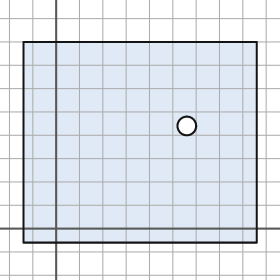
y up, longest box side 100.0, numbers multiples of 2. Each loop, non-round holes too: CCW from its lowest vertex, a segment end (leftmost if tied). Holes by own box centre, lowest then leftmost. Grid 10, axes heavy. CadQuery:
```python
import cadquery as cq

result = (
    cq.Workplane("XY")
    .moveTo(-14.0, -6.0)
    .lineTo(86.0, -6.0)
    .lineTo(86.0, 80.0)
    .lineTo(-14.0, 80.0)
    .close()
    .moveTo(56.0, 44.0)
    .circle(4.0)
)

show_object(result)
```